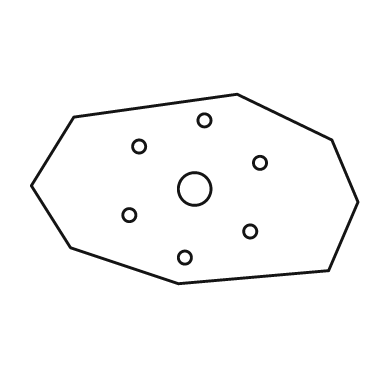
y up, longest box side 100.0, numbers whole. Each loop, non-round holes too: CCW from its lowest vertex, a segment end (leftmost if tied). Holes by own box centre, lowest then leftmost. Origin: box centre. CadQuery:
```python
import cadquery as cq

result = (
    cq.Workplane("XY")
    .moveTo(-5.0, -29.0)
    .lineTo(41.0, -25.0)
    .lineTo(50.0, -4.0)
    .lineTo(42.0, 15.0)
    .lineTo(13.0, 29.0)
    .lineTo(-37.0, 22.0)
    .lineTo(-50.0, 1.0)
    .lineTo(-38.0, -18.0)
    .close()
    .moveTo(-3.0, -21.0)
    .circle(2.0)
    .moveTo(17.0, -13.0)
    .circle(2.0)
    .moveTo(-20.0, -8.0)
    .circle(2.0)
    .moveTo(0.0, 0.0)
    .circle(5.0)
    .moveTo(20.0, 8.0)
    .circle(2.0)
    .moveTo(-17.0, 13.0)
    .circle(2.0)
    .moveTo(3.0, 21.0)
    .circle(2.0)
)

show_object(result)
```